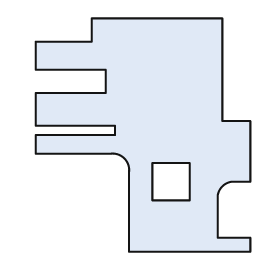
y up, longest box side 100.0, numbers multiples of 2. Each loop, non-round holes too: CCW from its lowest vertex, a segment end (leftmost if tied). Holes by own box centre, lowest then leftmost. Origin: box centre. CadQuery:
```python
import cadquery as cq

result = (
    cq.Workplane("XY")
    .moveTo(-6.0, -50.0)
    .lineTo(46.0, -50.0)
    .lineTo(46.0, -44.0)
    .lineTo(32.0, -44.0)
    .lineTo(32.0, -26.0)
    .threePointArc((34.0, -22.0), (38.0, -20.0))
    .lineTo(46.0, -20.0)
    .lineTo(46.0, 6.0)
    .lineTo(34.0, 6.0)
    .lineTo(34.0, 50.0)
    .lineTo(-22.0, 50.0)
    .lineTo(-22.0, 40.0)
    .lineTo(-46.0, 40.0)
    .lineTo(-46.0, 28.0)
    .lineTo(-16.0, 28.0)
    .lineTo(-16.0, 18.0)
    .lineTo(-46.0, 18.0)
    .lineTo(-46.0, 4.0)
    .lineTo(-12.0, 4.0)
    .lineTo(-12.0, 0.0)
    .lineTo(-46.0, 0.0)
    .lineTo(-46.0, -8.0)
    .lineTo(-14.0, -8.0)
    .threePointArc((-8.0, -10.0), (-6.0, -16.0))
    .close()
    .moveTo(4.0, -28.0)
    .lineTo(20.0, -28.0)
    .lineTo(20.0, -12.0)
    .lineTo(4.0, -12.0)
    .close()
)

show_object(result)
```